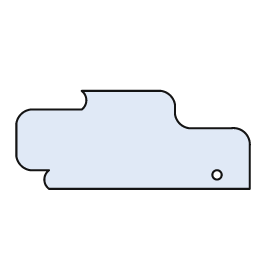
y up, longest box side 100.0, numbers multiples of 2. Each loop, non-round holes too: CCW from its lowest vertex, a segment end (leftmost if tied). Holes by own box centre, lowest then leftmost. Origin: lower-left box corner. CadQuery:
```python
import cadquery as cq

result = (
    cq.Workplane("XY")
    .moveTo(14.0, 0.0)
    .lineTo(100.0, 0.0)
    .lineTo(100.0, 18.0)
    .threePointArc((98.0, 24.0), (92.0, 26.0))
    .lineTo(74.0, 26.0)
    .threePointArc((70.0, 28.0), (68.0, 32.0))
    .lineTo(68.0, 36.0)
    .threePointArc((66.0, 40.0), (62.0, 42.0))
    .lineTo(28.0, 42.0)
    .threePointArc((30.0, 38.0), (28.0, 34.0))
    .lineTo(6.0, 34.0)
    .threePointArc((2.0, 32.0), (0.0, 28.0))
    .lineTo(0.0, 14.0)
    .threePointArc((2.0, 10.0), (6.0, 8.0))
    .lineTo(14.0, 8.0)
    .threePointArc((12.0, 4.0), (14.0, 0.0))
    .close()
    .moveTo(86.0, 6.0)
    .circle(2.0)
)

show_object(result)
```